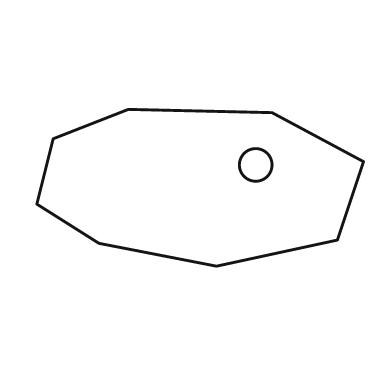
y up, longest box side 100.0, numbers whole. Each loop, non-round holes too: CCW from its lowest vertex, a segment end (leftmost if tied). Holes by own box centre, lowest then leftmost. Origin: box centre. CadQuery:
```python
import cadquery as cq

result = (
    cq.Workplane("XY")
    .moveTo(5.0, -24.0)
    .lineTo(42.0, -16.0)
    .lineTo(50.0, 8.0)
    .lineTo(22.0, 23.0)
    .lineTo(-22.0, 24.0)
    .lineTo(-45.0, 15.0)
    .lineTo(-50.0, -5.0)
    .lineTo(-31.0, -17.0)
    .close()
    .moveTo(17.0, 7.0)
    .circle(5.0)
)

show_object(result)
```